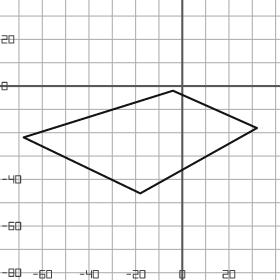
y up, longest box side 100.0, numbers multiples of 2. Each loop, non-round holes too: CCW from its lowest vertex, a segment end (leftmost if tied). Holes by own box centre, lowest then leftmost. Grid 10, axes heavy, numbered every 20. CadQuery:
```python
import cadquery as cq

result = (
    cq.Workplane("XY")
    .moveTo(-18.0, -46.0)
    .lineTo(32.0, -18.0)
    .lineTo(-4.0, -2.0)
    .lineTo(-68.0, -22.0)
    .close()
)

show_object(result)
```